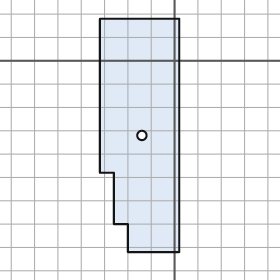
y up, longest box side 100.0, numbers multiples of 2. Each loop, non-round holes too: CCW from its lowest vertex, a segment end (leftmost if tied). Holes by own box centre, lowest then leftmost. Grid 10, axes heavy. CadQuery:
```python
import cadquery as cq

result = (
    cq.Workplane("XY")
    .moveTo(-20.0, -82.0)
    .lineTo(2.0, -82.0)
    .lineTo(2.0, 18.0)
    .lineTo(-32.0, 18.0)
    .lineTo(-32.0, -48.0)
    .lineTo(-26.0, -48.0)
    .lineTo(-26.0, -70.0)
    .lineTo(-20.0, -70.0)
    .close()
    .moveTo(-14.0, -32.0)
    .circle(2.0)
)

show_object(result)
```